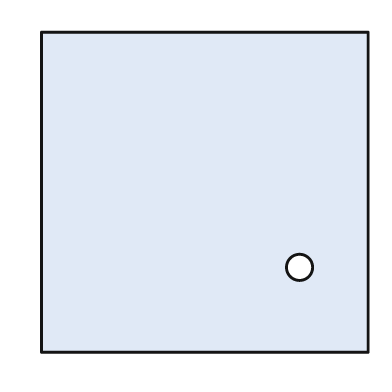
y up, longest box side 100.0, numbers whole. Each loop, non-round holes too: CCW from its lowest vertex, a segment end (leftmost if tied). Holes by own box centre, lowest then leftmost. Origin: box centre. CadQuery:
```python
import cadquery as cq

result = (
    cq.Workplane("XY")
    .moveTo(-50.0, -49.0)
    .lineTo(50.0, -49.0)
    .lineTo(50.0, 49.0)
    .lineTo(-50.0, 49.0)
    .close()
    .moveTo(29.0, -23.0)
    .circle(4.0)
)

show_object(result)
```